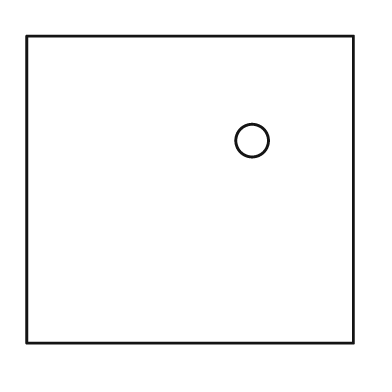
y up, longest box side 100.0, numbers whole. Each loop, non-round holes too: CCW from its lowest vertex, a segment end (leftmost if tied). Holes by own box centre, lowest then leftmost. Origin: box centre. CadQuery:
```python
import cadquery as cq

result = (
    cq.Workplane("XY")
    .moveTo(-50.0, -47.0)
    .lineTo(50.0, -47.0)
    .lineTo(50.0, 47.0)
    .lineTo(-50.0, 47.0)
    .close()
    .moveTo(19.0, 15.0)
    .circle(5.0)
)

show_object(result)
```